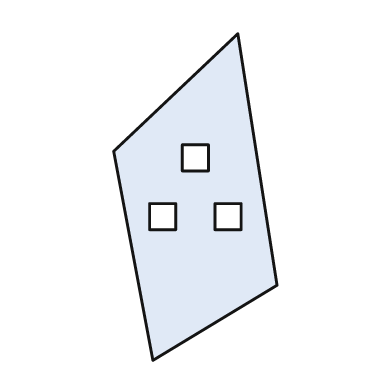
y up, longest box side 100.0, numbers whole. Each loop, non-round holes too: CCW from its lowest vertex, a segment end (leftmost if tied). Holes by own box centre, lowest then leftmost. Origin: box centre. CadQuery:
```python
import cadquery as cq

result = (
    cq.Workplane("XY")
    .moveTo(-13.0, -50.0)
    .lineTo(25.0, -27.0)
    .lineTo(13.0, 50.0)
    .lineTo(-25.0, 14.0)
    .close()
    .moveTo(-14.0, -10.0)
    .lineTo(-6.0, -10.0)
    .lineTo(-6.0, -2.0)
    .lineTo(-14.0, -2.0)
    .close()
    .moveTo(6.0, -10.0)
    .lineTo(14.0, -10.0)
    .lineTo(14.0, -2.0)
    .lineTo(6.0, -2.0)
    .close()
    .moveTo(-4.0, 8.0)
    .lineTo(4.0, 8.0)
    .lineTo(4.0, 16.0)
    .lineTo(-4.0, 16.0)
    .close()
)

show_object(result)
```